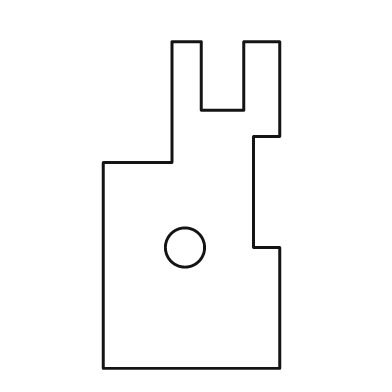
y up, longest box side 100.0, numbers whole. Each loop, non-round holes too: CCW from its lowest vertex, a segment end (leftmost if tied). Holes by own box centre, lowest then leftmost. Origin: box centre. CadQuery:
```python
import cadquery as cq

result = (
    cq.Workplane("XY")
    .moveTo(-27.0, -50.0)
    .lineTo(27.0, -50.0)
    .lineTo(27.0, -13.0)
    .lineTo(19.0, -13.0)
    .lineTo(19.0, 21.0)
    .lineTo(27.0, 21.0)
    .lineTo(27.0, 50.0)
    .lineTo(16.0, 50.0)
    .lineTo(16.0, 29.0)
    .lineTo(3.0, 29.0)
    .lineTo(3.0, 50.0)
    .lineTo(-6.0, 50.0)
    .lineTo(-6.0, 13.0)
    .lineTo(-27.0, 13.0)
    .close()
    .moveTo(-2.0, -13.0)
    .circle(6.0)
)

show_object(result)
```